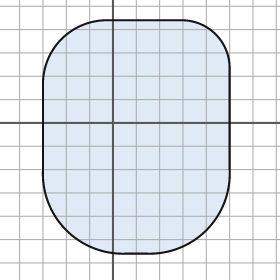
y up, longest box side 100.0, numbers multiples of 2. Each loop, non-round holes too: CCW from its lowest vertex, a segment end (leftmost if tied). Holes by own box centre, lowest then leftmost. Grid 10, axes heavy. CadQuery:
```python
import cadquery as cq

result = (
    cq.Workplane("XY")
    .moveTo(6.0, -56.0)
    .lineTo(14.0, -56.0)
    .threePointArc((40.0, -46.0), (50.0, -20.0))
    .lineTo(50.0, 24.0)
    .threePointArc((44.0, 38.0), (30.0, 44.0))
    .lineTo(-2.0, 44.0)
    .threePointArc((-22.0, 36.0), (-30.0, 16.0))
    .lineTo(-30.0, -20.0)
    .threePointArc((-20.0, -46.0), (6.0, -56.0))
    .close()
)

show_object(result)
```